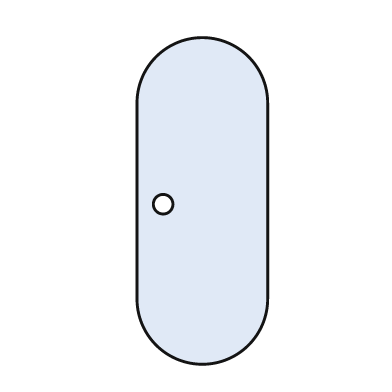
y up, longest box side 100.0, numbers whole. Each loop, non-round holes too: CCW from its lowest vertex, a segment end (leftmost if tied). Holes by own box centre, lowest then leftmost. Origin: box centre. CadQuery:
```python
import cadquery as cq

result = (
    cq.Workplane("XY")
    .moveTo(-20.0, -30.0)
    .threePointArc((0.0, -50.0), (20.0, -30.0))
    .lineTo(20.0, 30.0)
    .threePointArc((0.0, 50.0), (-20.0, 30.0))
    .close()
    .moveTo(-12.0, -1.0)
    .circle(3.0)
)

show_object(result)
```